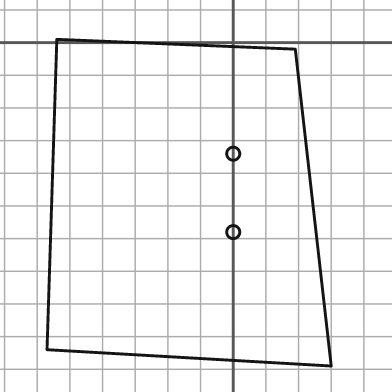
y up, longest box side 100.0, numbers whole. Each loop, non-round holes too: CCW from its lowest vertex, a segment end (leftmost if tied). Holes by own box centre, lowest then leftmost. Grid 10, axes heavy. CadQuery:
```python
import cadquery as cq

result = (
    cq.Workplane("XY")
    .moveTo(30.0, -99.0)
    .lineTo(19.0, -2.0)
    .lineTo(-54.0, 1.0)
    .lineTo(-57.0, -94.0)
    .close()
    .moveTo(0.0, -58.0)
    .circle(2.0)
    .moveTo(0.0, -34.0)
    .circle(2.0)
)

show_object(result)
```